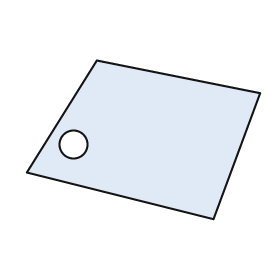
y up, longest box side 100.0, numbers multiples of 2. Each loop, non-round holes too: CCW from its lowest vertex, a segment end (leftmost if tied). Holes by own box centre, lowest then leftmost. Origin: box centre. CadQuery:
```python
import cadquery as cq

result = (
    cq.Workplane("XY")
    .moveTo(30.0, -34.0)
    .lineTo(50.0, 20.0)
    .lineTo(-20.0, 34.0)
    .lineTo(-50.0, -14.0)
    .close()
    .moveTo(-30.0, -2.0)
    .circle(6.0)
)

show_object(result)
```